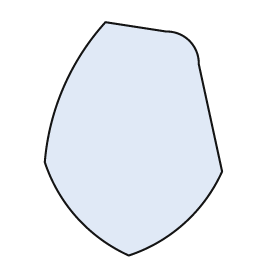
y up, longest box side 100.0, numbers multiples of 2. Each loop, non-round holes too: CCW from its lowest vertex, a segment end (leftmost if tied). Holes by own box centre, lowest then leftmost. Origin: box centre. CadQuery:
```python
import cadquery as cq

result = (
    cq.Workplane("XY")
    .moveTo(-2.0, -50.0)
    .threePointArc((22.0, -36.0), (38.0, -14.0))
    .lineTo(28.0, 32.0)
    .threePointArc((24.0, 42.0), (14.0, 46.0))
    .lineTo(-12.0, 50.0)
    .threePointArc((-30.0, 22.0), (-38.0, -10.0))
    .threePointArc((-24.0, -34.0), (-2.0, -50.0))
    .close()
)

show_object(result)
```